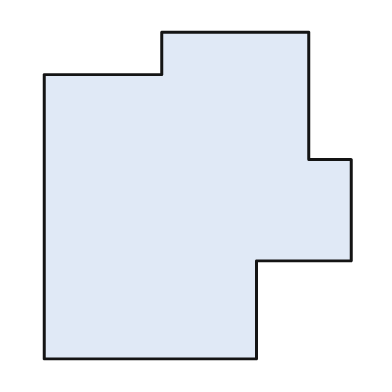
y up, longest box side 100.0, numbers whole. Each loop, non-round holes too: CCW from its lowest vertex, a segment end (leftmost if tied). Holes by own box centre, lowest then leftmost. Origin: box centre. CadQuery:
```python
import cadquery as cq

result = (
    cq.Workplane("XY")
    .moveTo(-47.0, -50.0)
    .lineTo(18.0, -50.0)
    .lineTo(18.0, -20.0)
    .lineTo(47.0, -20.0)
    .lineTo(47.0, 11.0)
    .lineTo(34.0, 11.0)
    .lineTo(34.0, 50.0)
    .lineTo(-11.0, 50.0)
    .lineTo(-11.0, 37.0)
    .lineTo(-47.0, 37.0)
    .close()
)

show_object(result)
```